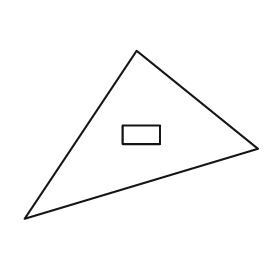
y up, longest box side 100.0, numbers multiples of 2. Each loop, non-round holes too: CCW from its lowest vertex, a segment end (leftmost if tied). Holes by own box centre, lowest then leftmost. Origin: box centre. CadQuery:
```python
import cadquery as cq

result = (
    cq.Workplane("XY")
    .moveTo(-50.0, -36.0)
    .lineTo(50.0, -6.0)
    .lineTo(-2.0, 36.0)
    .close()
    .moveTo(-8.0, -4.0)
    .lineTo(8.0, -4.0)
    .lineTo(8.0, 4.0)
    .lineTo(-8.0, 4.0)
    .close()
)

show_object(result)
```